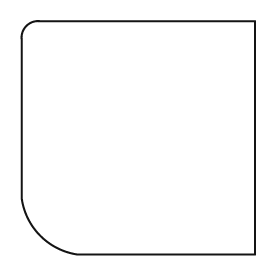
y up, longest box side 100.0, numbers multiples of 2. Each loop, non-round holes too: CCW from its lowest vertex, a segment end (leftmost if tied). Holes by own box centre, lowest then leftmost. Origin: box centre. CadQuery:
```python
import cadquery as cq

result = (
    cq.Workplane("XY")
    .moveTo(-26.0, -50.0)
    .lineTo(50.0, -50.0)
    .lineTo(50.0, 50.0)
    .lineTo(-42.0, 50.0)
    .threePointArc((-48.0, 48.0), (-50.0, 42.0))
    .lineTo(-50.0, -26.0)
    .threePointArc((-42.0, -42.0), (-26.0, -50.0))
    .close()
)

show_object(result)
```